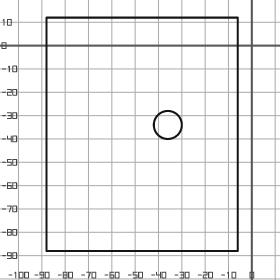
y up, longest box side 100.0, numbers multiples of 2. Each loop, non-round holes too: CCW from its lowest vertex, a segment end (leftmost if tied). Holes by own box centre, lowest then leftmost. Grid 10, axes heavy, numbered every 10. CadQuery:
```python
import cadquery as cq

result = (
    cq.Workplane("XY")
    .moveTo(-88.0, -88.0)
    .lineTo(-6.0, -88.0)
    .lineTo(-6.0, 12.0)
    .lineTo(-88.0, 12.0)
    .close()
    .moveTo(-36.0, -34.0)
    .circle(6.0)
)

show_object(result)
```